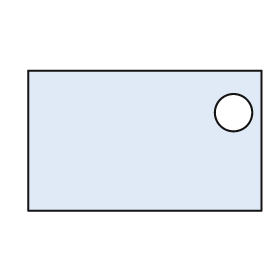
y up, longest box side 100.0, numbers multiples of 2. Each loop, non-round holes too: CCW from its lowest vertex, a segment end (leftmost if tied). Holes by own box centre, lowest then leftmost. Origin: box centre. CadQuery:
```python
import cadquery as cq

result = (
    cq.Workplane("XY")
    .moveTo(-50.0, -30.0)
    .lineTo(50.0, -30.0)
    .lineTo(50.0, 30.0)
    .lineTo(-50.0, 30.0)
    .close()
    .moveTo(38.0, 12.0)
    .circle(8.0)
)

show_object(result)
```